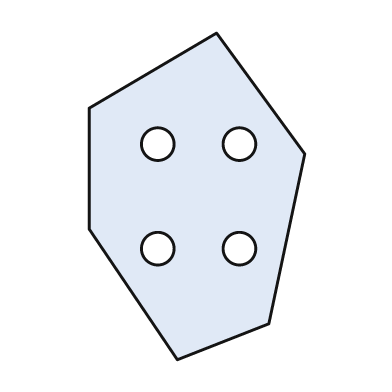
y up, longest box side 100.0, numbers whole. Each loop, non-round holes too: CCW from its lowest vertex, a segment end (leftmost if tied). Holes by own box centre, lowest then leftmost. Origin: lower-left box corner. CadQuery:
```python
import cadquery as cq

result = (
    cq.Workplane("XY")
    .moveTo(27.0, 0.0)
    .lineTo(55.0, 11.0)
    .lineTo(66.0, 63.0)
    .lineTo(39.0, 100.0)
    .lineTo(0.0, 77.0)
    .lineTo(0.0, 40.0)
    .close()
    .moveTo(21.0, 34.0)
    .circle(5.0)
    .moveTo(46.0, 34.0)
    .circle(5.0)
    .moveTo(21.0, 66.0)
    .circle(5.0)
    .moveTo(46.0, 66.0)
    .circle(5.0)
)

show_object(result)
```